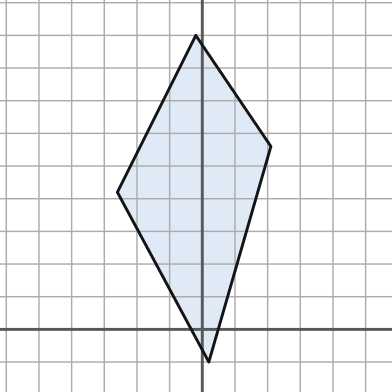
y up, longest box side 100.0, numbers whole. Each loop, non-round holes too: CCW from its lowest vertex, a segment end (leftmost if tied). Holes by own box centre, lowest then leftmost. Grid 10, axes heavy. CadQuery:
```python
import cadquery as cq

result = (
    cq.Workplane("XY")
    .moveTo(2.0, -10.0)
    .lineTo(21.0, 56.0)
    .lineTo(-2.0, 90.0)
    .lineTo(-26.0, 42.0)
    .close()
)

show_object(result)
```